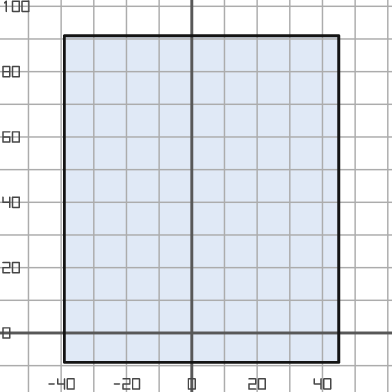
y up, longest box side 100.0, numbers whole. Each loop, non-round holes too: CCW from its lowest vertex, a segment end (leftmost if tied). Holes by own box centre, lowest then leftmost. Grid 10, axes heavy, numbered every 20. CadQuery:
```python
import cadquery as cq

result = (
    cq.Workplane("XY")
    .moveTo(-39.0, -9.0)
    .lineTo(45.0, -9.0)
    .lineTo(45.0, 91.0)
    .lineTo(-39.0, 91.0)
    .close()
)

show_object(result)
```